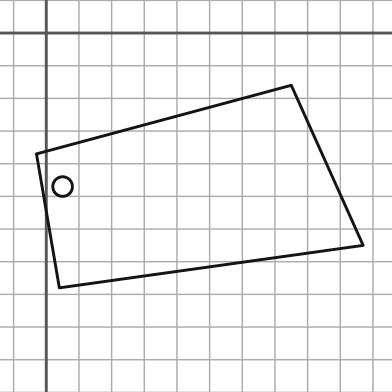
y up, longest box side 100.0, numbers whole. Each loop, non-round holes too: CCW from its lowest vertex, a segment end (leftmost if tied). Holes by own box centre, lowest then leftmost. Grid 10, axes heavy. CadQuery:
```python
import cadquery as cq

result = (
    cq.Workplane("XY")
    .moveTo(4.0, -78.0)
    .lineTo(97.0, -65.0)
    .lineTo(75.0, -16.0)
    .lineTo(-3.0, -37.0)
    .close()
    .moveTo(5.0, -47.0)
    .circle(3.0)
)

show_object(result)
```